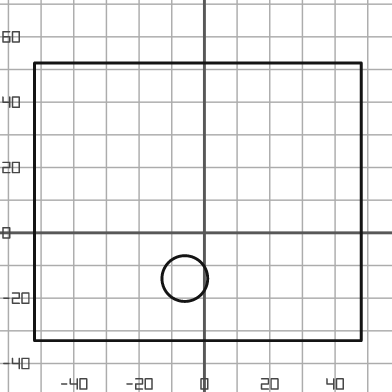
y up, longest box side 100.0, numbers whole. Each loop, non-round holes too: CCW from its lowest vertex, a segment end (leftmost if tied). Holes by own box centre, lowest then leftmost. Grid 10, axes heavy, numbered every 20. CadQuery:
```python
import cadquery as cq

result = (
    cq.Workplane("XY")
    .moveTo(-52.0, -33.0)
    .lineTo(48.0, -33.0)
    .lineTo(48.0, 52.0)
    .lineTo(-52.0, 52.0)
    .close()
    .moveTo(-6.0, -14.0)
    .circle(7.0)
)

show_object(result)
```